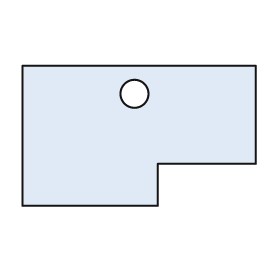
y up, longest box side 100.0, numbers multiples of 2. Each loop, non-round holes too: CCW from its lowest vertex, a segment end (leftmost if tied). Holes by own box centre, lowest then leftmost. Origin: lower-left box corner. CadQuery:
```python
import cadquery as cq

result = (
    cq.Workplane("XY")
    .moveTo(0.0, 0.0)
    .lineTo(58.0, 0.0)
    .lineTo(58.0, 18.0)
    .lineTo(100.0, 18.0)
    .lineTo(100.0, 60.0)
    .lineTo(0.0, 60.0)
    .close()
    .moveTo(48.0, 48.0)
    .circle(6.0)
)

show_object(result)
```